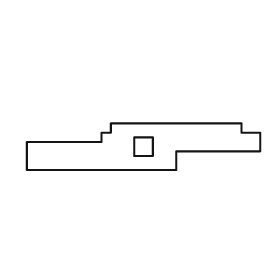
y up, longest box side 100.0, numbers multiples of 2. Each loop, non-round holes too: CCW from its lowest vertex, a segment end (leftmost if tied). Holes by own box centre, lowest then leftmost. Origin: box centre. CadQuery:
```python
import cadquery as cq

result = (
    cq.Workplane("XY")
    .moveTo(-50.0, -10.0)
    .lineTo(14.0, -10.0)
    .lineTo(14.0, -2.0)
    .lineTo(50.0, -2.0)
    .lineTo(50.0, 6.0)
    .lineTo(42.0, 6.0)
    .lineTo(42.0, 10.0)
    .lineTo(-14.0, 10.0)
    .lineTo(-14.0, 6.0)
    .lineTo(-18.0, 6.0)
    .lineTo(-18.0, 2.0)
    .lineTo(-50.0, 2.0)
    .close()
    .moveTo(-4.0, -4.0)
    .lineTo(4.0, -4.0)
    .lineTo(4.0, 4.0)
    .lineTo(-4.0, 4.0)
    .close()
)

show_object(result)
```